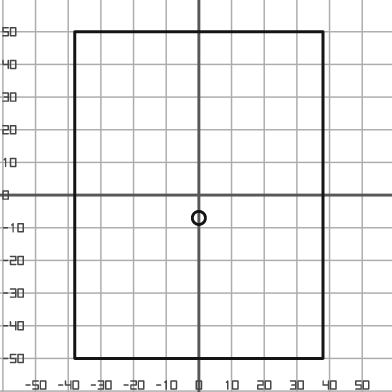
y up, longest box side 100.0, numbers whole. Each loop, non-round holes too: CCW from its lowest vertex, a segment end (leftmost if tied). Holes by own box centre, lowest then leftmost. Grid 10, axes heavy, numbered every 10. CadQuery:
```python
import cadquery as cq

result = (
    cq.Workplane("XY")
    .moveTo(-38.0, -50.0)
    .lineTo(38.0, -50.0)
    .lineTo(38.0, 50.0)
    .lineTo(-38.0, 50.0)
    .close()
    .moveTo(0.0, -7.0)
    .circle(2.0)
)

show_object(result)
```